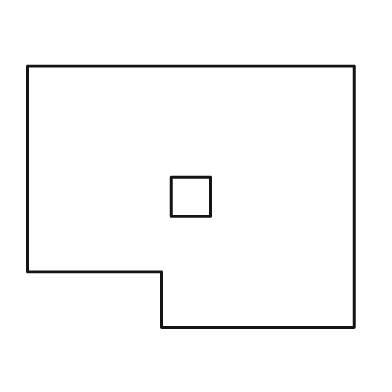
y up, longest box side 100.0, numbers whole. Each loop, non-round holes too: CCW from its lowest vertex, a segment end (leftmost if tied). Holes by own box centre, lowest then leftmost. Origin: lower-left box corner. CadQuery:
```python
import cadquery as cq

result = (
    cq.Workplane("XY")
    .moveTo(41.0, 0.0)
    .lineTo(100.0, 0.0)
    .lineTo(100.0, 80.0)
    .lineTo(0.0, 80.0)
    .lineTo(0.0, 17.0)
    .lineTo(41.0, 17.0)
    .close()
    .moveTo(44.0, 34.0)
    .lineTo(56.0, 34.0)
    .lineTo(56.0, 46.0)
    .lineTo(44.0, 46.0)
    .close()
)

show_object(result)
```